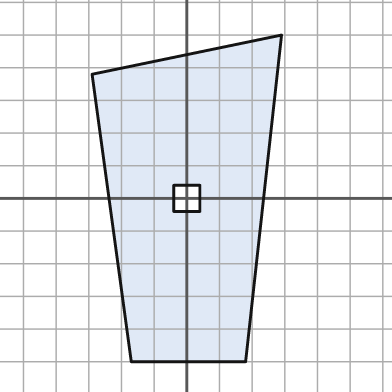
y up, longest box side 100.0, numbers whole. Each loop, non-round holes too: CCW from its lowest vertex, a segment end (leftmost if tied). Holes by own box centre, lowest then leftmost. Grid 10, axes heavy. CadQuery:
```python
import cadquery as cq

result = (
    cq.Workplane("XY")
    .moveTo(-17.0, -50.0)
    .lineTo(18.0, -50.0)
    .lineTo(29.0, 50.0)
    .lineTo(-29.0, 38.0)
    .close()
    .moveTo(-4.0, -4.0)
    .lineTo(4.0, -4.0)
    .lineTo(4.0, 4.0)
    .lineTo(-4.0, 4.0)
    .close()
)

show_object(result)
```